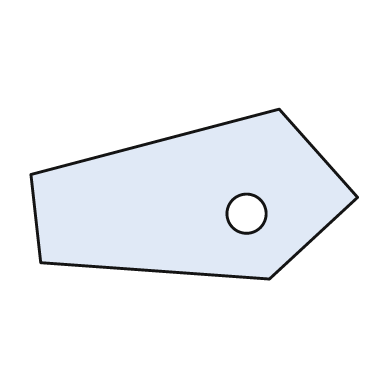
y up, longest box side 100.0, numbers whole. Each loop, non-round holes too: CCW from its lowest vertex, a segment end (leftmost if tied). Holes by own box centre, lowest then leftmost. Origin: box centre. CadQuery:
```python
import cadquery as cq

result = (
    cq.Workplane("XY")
    .moveTo(23.0, -26.0)
    .lineTo(50.0, -1.0)
    .lineTo(26.0, 26.0)
    .lineTo(-50.0, 6.0)
    .lineTo(-47.0, -21.0)
    .close()
    .moveTo(16.0, -6.0)
    .circle(6.0)
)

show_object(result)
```